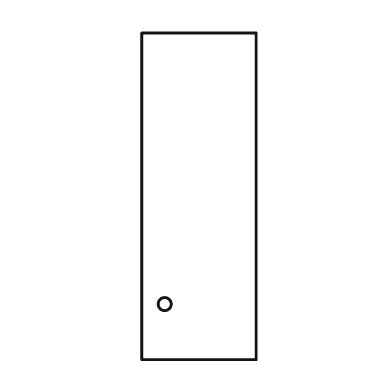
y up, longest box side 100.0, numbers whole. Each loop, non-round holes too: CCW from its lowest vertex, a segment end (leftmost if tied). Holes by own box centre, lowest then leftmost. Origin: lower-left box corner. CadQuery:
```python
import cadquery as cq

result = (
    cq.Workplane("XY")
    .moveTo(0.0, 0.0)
    .lineTo(35.0, 0.0)
    .lineTo(35.0, 100.0)
    .lineTo(0.0, 100.0)
    .close()
    .moveTo(7.0, 17.0)
    .circle(2.0)
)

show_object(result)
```